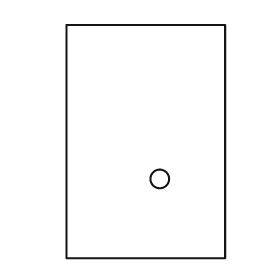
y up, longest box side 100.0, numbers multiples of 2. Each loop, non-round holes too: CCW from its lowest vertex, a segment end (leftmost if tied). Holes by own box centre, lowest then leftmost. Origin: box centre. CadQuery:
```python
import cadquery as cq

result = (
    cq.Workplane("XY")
    .moveTo(-34.0, -50.0)
    .lineTo(34.0, -50.0)
    .lineTo(34.0, 50.0)
    .lineTo(-34.0, 50.0)
    .close()
    .moveTo(6.0, -16.0)
    .circle(4.0)
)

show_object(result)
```